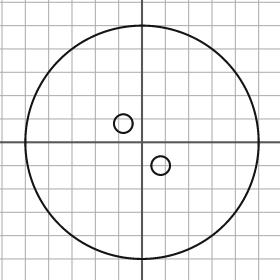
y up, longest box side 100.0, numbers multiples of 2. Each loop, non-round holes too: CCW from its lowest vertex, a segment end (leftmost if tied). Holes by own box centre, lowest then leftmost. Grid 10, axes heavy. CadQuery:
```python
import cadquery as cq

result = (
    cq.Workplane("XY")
    .moveTo(0.0, 0.0)
    .circle(50.0)
    .moveTo(8.0, -10.0)
    .circle(4.0)
    .moveTo(-8.0, 8.0)
    .circle(4.0)
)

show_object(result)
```